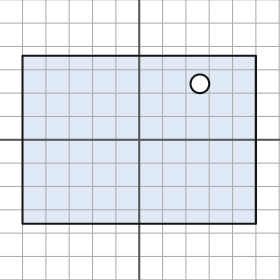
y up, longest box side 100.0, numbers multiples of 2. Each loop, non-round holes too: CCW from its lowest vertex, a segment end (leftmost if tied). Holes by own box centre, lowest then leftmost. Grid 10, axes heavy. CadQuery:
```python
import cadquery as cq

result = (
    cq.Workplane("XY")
    .moveTo(-50.0, -36.0)
    .lineTo(50.0, -36.0)
    .lineTo(50.0, 36.0)
    .lineTo(-50.0, 36.0)
    .close()
    .moveTo(26.0, 24.0)
    .circle(4.0)
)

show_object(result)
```